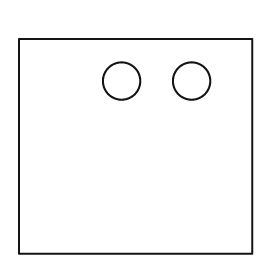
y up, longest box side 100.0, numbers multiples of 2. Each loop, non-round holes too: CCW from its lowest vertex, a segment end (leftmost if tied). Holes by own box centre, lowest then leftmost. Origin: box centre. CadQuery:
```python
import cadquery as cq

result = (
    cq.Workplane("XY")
    .moveTo(-50.0, -46.0)
    .lineTo(50.0, -46.0)
    .lineTo(50.0, 46.0)
    .lineTo(-50.0, 46.0)
    .close()
    .moveTo(-6.0, 28.0)
    .circle(8.0)
    .moveTo(24.0, 28.0)
    .circle(8.0)
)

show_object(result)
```